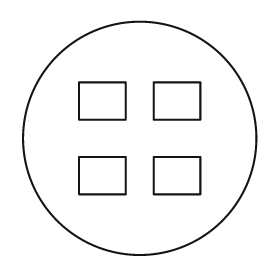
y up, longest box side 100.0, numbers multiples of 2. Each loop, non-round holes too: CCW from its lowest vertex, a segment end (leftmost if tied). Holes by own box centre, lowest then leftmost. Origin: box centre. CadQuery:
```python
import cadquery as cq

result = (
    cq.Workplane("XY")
    .moveTo(0.0, 0.0)
    .circle(50.0)
    .moveTo(-26.0, -24.0)
    .lineTo(-6.0, -24.0)
    .lineTo(-6.0, -8.0)
    .lineTo(-26.0, -8.0)
    .close()
    .moveTo(6.0, -24.0)
    .lineTo(26.0, -24.0)
    .lineTo(26.0, -8.0)
    .lineTo(6.0, -8.0)
    .close()
    .moveTo(-26.0, 8.0)
    .lineTo(-6.0, 8.0)
    .lineTo(-6.0, 24.0)
    .lineTo(-26.0, 24.0)
    .close()
    .moveTo(6.0, 8.0)
    .lineTo(26.0, 8.0)
    .lineTo(26.0, 24.0)
    .lineTo(6.0, 24.0)
    .close()
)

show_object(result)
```